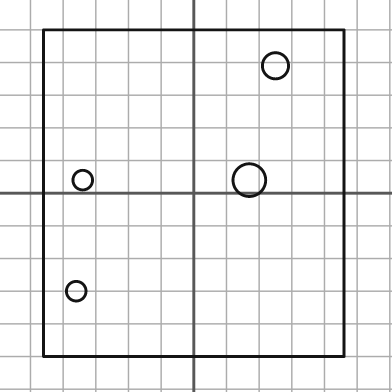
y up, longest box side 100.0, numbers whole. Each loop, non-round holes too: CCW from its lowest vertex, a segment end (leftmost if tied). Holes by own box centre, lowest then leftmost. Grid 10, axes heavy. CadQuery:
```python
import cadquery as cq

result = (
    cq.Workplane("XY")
    .moveTo(-46.0, -50.0)
    .lineTo(46.0, -50.0)
    .lineTo(46.0, 50.0)
    .lineTo(-46.0, 50.0)
    .close()
    .moveTo(-36.0, -30.0)
    .circle(3.0)
    .moveTo(-34.0, 4.0)
    .circle(3.0)
    .moveTo(17.0, 4.0)
    .circle(5.0)
    .moveTo(25.0, 39.0)
    .circle(4.0)
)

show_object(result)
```